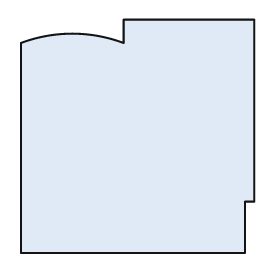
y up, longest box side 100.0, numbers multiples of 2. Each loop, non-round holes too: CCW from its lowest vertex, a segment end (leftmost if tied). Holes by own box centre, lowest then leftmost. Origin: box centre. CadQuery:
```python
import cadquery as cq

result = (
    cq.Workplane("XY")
    .moveTo(-50.0, -50.0)
    .lineTo(46.0, -50.0)
    .lineTo(46.0, -28.0)
    .lineTo(50.0, -28.0)
    .lineTo(50.0, 50.0)
    .lineTo(-6.0, 50.0)
    .lineTo(-6.0, 40.0)
    .threePointArc((-28.0, 44.0), (-50.0, 40.0))
    .close()
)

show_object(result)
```